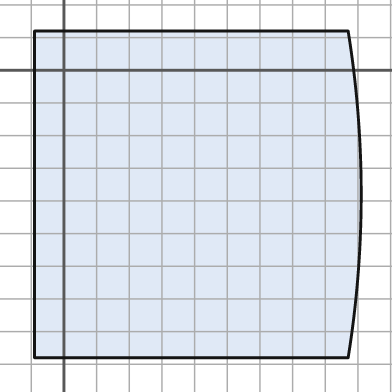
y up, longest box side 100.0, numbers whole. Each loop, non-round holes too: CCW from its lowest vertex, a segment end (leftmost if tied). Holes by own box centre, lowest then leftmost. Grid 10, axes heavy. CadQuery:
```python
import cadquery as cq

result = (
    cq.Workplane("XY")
    .moveTo(-9.0, -88.0)
    .lineTo(87.0, -88.0)
    .threePointArc((91.0, -38.0), (87.0, 12.0))
    .lineTo(-9.0, 12.0)
    .close()
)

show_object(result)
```